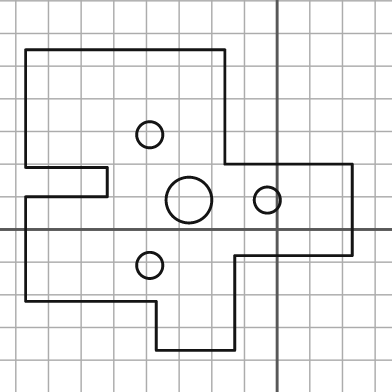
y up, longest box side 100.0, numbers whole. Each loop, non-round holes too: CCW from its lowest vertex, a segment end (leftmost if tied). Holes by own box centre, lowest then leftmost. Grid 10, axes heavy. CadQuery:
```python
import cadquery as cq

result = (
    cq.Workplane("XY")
    .moveTo(-37.0, -37.0)
    .lineTo(-13.0, -37.0)
    .lineTo(-13.0, -8.0)
    .lineTo(23.0, -8.0)
    .lineTo(23.0, 20.0)
    .lineTo(-16.0, 20.0)
    .lineTo(-16.0, 55.0)
    .lineTo(-77.0, 55.0)
    .lineTo(-77.0, 19.0)
    .lineTo(-52.0, 19.0)
    .lineTo(-52.0, 10.0)
    .lineTo(-77.0, 10.0)
    .lineTo(-77.0, -22.0)
    .lineTo(-37.0, -22.0)
    .close()
    .moveTo(-39.0, -11.0)
    .circle(4.0)
    .moveTo(-27.0, 9.0)
    .circle(7.0)
    .moveTo(-3.0, 9.0)
    .circle(4.0)
    .moveTo(-39.0, 29.0)
    .circle(4.0)
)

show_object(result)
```